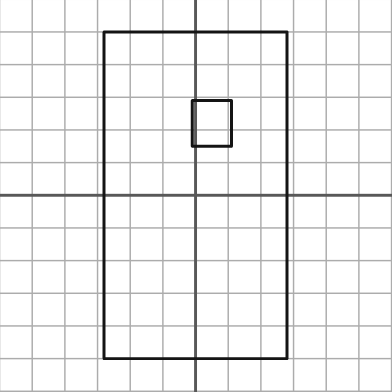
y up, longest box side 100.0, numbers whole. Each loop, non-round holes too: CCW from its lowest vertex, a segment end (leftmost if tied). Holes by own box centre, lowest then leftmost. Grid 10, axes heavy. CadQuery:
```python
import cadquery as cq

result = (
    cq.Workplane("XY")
    .moveTo(-28.0, -50.0)
    .lineTo(28.0, -50.0)
    .lineTo(28.0, 50.0)
    .lineTo(-28.0, 50.0)
    .close()
    .moveTo(-1.0, 15.0)
    .lineTo(11.0, 15.0)
    .lineTo(11.0, 29.0)
    .lineTo(-1.0, 29.0)
    .close()
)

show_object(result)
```